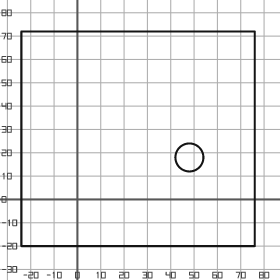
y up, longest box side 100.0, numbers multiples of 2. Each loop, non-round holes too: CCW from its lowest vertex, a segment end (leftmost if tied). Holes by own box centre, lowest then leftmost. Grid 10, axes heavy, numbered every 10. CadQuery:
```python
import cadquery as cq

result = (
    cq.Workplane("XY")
    .moveTo(-24.0, -20.0)
    .lineTo(76.0, -20.0)
    .lineTo(76.0, 72.0)
    .lineTo(-24.0, 72.0)
    .close()
    .moveTo(48.0, 18.0)
    .circle(6.0)
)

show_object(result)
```